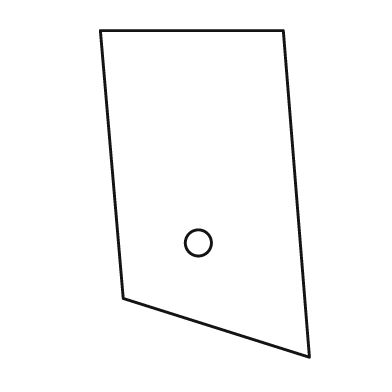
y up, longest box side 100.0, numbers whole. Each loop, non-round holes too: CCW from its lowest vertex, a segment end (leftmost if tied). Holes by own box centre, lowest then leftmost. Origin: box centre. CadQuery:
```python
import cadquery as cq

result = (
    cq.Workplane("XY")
    .moveTo(32.0, -50.0)
    .lineTo(24.0, 50.0)
    .lineTo(-32.0, 50.0)
    .lineTo(-25.0, -32.0)
    .close()
    .moveTo(-2.0, -15.0)
    .circle(4.0)
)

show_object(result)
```